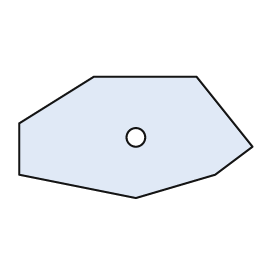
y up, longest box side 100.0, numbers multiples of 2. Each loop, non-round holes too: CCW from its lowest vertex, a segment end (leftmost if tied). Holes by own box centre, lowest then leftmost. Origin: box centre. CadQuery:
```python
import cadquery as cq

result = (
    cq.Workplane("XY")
    .moveTo(0.0, -26.0)
    .lineTo(34.0, -16.0)
    .lineTo(50.0, -4.0)
    .lineTo(26.0, 26.0)
    .lineTo(-18.0, 26.0)
    .lineTo(-50.0, 6.0)
    .lineTo(-50.0, -16.0)
    .close()
    .moveTo(0.0, 0.0)
    .circle(4.0)
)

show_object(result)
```